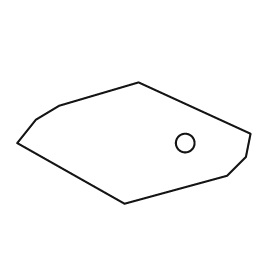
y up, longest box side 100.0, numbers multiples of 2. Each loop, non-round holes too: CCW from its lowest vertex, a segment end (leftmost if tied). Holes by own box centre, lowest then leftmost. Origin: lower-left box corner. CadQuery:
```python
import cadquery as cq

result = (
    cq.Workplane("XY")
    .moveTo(46.0, 0.0)
    .lineTo(90.0, 12.0)
    .lineTo(98.0, 20.0)
    .lineTo(100.0, 30.0)
    .lineTo(52.0, 52.0)
    .lineTo(18.0, 42.0)
    .lineTo(8.0, 36.0)
    .lineTo(0.0, 26.0)
    .close()
    .moveTo(72.0, 26.0)
    .circle(4.0)
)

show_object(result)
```